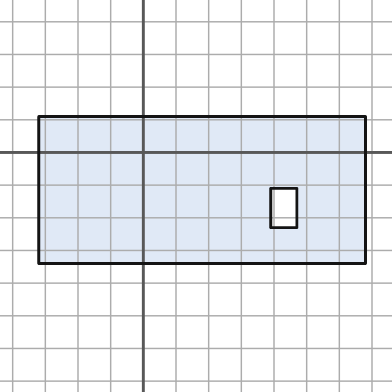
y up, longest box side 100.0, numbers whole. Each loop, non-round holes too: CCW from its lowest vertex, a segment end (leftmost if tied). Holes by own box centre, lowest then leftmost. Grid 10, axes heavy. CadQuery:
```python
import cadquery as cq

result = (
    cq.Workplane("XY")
    .moveTo(-32.0, -34.0)
    .lineTo(68.0, -34.0)
    .lineTo(68.0, 11.0)
    .lineTo(-32.0, 11.0)
    .close()
    .moveTo(39.0, -23.0)
    .lineTo(47.0, -23.0)
    .lineTo(47.0, -11.0)
    .lineTo(39.0, -11.0)
    .close()
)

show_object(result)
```